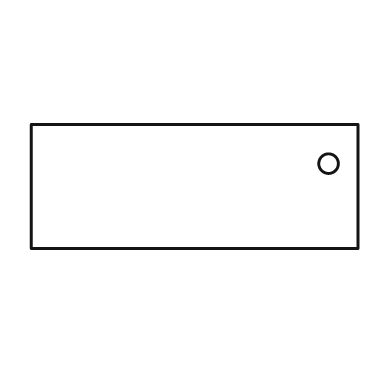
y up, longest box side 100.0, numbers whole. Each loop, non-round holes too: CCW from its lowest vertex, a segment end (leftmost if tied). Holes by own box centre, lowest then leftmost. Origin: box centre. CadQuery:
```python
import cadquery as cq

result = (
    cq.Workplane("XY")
    .moveTo(-50.0, -19.0)
    .lineTo(50.0, -19.0)
    .lineTo(50.0, 19.0)
    .lineTo(-50.0, 19.0)
    .close()
    .moveTo(41.0, 7.0)
    .circle(3.0)
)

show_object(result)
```